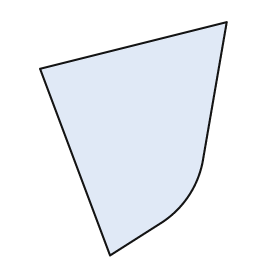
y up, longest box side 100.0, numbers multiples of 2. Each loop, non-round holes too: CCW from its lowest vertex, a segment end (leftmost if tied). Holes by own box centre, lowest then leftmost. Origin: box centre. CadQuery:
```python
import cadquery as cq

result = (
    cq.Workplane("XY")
    .moveTo(-10.0, -50.0)
    .lineTo(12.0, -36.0)
    .threePointArc((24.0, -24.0), (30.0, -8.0))
    .lineTo(40.0, 50.0)
    .lineTo(-40.0, 30.0)
    .close()
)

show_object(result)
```